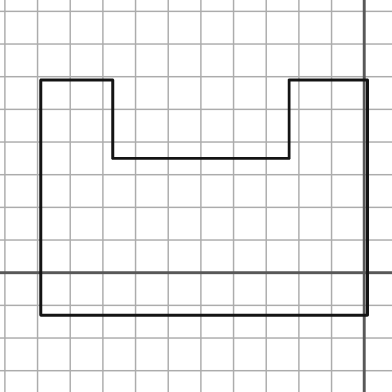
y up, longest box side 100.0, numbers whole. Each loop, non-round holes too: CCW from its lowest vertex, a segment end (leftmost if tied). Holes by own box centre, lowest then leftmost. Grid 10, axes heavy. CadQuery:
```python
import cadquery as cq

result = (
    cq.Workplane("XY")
    .moveTo(-99.0, -13.0)
    .lineTo(1.0, -13.0)
    .lineTo(1.0, 59.0)
    .lineTo(-23.0, 59.0)
    .lineTo(-23.0, 35.0)
    .lineTo(-77.0, 35.0)
    .lineTo(-77.0, 59.0)
    .lineTo(-99.0, 59.0)
    .close()
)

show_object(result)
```